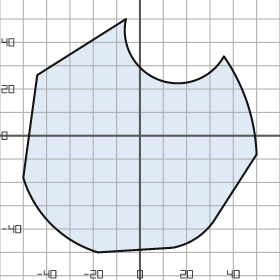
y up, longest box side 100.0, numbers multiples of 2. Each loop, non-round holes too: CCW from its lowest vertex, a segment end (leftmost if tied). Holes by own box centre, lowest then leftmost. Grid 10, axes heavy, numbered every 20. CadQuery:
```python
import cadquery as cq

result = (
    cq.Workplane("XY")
    .moveTo(-18.0, -50.0)
    .lineTo(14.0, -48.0)
    .threePointArc((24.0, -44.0), (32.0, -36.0))
    .lineTo(50.0, -8.0)
    .threePointArc((46.0, 14.0), (36.0, 34.0))
    .threePointArc((8.0, 24.0), (-6.0, 50.0))
    .lineTo(-44.0, 26.0)
    .lineTo(-50.0, -18.0)
    .threePointArc((-38.0, -38.0), (-18.0, -50.0))
    .close()
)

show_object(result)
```